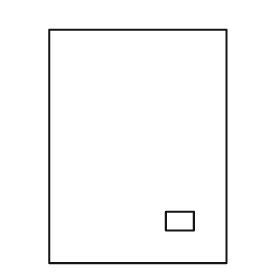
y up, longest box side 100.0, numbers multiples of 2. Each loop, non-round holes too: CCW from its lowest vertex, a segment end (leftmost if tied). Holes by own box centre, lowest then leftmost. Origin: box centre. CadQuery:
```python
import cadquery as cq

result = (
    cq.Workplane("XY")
    .moveTo(-38.0, -50.0)
    .lineTo(38.0, -50.0)
    .lineTo(38.0, 50.0)
    .lineTo(-38.0, 50.0)
    .close()
    .moveTo(12.0, -36.0)
    .lineTo(24.0, -36.0)
    .lineTo(24.0, -28.0)
    .lineTo(12.0, -28.0)
    .close()
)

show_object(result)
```